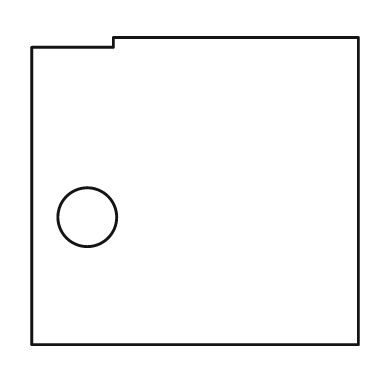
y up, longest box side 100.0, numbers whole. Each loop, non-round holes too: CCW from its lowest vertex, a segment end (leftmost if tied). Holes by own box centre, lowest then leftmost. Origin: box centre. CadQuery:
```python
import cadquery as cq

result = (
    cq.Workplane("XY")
    .moveTo(-50.0, -47.0)
    .lineTo(50.0, -47.0)
    .lineTo(50.0, 47.0)
    .lineTo(-25.0, 47.0)
    .lineTo(-25.0, 44.0)
    .lineTo(-50.0, 44.0)
    .close()
    .moveTo(-33.0, -8.0)
    .circle(9.0)
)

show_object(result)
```